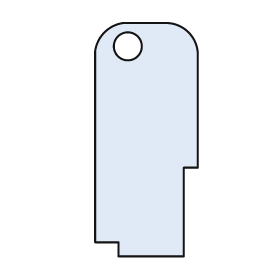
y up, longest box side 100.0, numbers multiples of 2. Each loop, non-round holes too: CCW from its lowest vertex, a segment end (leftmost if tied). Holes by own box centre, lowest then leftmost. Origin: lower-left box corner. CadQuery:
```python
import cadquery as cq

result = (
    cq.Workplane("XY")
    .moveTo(10.0, 0.0)
    .lineTo(38.0, 0.0)
    .lineTo(38.0, 38.0)
    .lineTo(44.0, 38.0)
    .lineTo(44.0, 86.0)
    .threePointArc((40.0, 96.0), (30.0, 100.0))
    .lineTo(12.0, 100.0)
    .threePointArc((4.0, 96.0), (0.0, 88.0))
    .lineTo(0.0, 6.0)
    .lineTo(10.0, 6.0)
    .close()
    .moveTo(14.0, 90.0)
    .circle(6.0)
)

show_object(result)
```